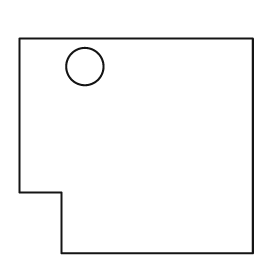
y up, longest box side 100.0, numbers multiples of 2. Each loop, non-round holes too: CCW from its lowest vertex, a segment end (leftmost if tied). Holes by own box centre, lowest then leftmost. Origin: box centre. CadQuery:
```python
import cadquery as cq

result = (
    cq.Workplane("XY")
    .moveTo(-32.0, -46.0)
    .lineTo(50.0, -46.0)
    .lineTo(50.0, 46.0)
    .lineTo(-50.0, 46.0)
    .lineTo(-50.0, -20.0)
    .lineTo(-32.0, -20.0)
    .close()
    .moveTo(-22.0, 34.0)
    .circle(8.0)
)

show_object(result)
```